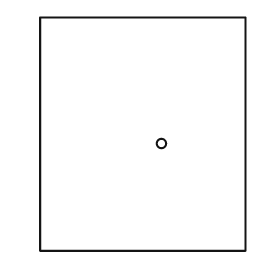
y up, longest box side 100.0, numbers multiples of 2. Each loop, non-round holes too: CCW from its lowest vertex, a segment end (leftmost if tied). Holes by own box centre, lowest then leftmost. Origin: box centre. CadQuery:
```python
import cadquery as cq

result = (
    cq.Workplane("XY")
    .moveTo(-44.0, -50.0)
    .lineTo(44.0, -50.0)
    .lineTo(44.0, 50.0)
    .lineTo(-44.0, 50.0)
    .close()
    .moveTo(8.0, -4.0)
    .circle(2.0)
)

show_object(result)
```